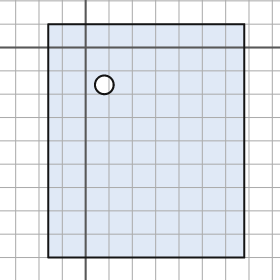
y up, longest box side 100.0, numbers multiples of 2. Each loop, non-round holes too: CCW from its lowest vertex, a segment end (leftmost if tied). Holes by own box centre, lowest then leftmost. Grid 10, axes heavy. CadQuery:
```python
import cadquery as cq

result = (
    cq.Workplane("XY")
    .moveTo(-16.0, -90.0)
    .lineTo(68.0, -90.0)
    .lineTo(68.0, 10.0)
    .lineTo(-16.0, 10.0)
    .close()
    .moveTo(8.0, -16.0)
    .circle(4.0)
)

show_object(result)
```